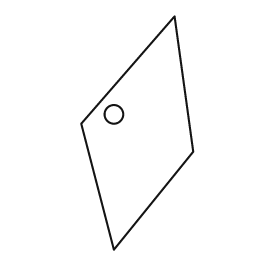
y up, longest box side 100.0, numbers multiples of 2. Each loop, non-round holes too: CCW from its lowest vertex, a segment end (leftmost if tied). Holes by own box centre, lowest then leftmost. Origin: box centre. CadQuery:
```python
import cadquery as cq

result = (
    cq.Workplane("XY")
    .moveTo(-10.0, -50.0)
    .lineTo(24.0, -8.0)
    .lineTo(16.0, 50.0)
    .lineTo(-24.0, 4.0)
    .close()
    .moveTo(-10.0, 8.0)
    .circle(4.0)
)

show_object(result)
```